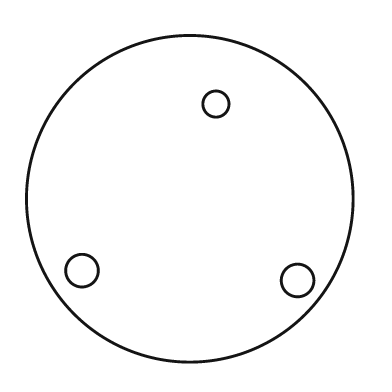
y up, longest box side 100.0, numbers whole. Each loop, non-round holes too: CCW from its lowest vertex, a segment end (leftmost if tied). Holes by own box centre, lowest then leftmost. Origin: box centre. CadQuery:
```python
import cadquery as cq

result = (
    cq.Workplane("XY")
    .moveTo(0.0, 0.0)
    .circle(50.0)
    .moveTo(33.0, -25.0)
    .circle(5.0)
    .moveTo(-33.0, -22.0)
    .circle(5.0)
    .moveTo(8.0, 29.0)
    .circle(4.0)
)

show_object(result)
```